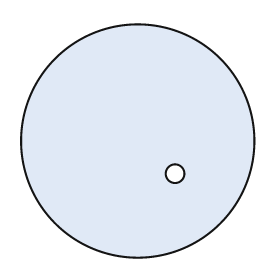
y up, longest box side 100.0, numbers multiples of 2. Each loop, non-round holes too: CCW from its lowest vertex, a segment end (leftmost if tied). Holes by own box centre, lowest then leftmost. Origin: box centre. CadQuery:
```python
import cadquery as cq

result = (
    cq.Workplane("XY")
    .moveTo(0.0, 0.0)
    .circle(50.0)
    .moveTo(16.0, -14.0)
    .circle(4.0)
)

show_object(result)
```